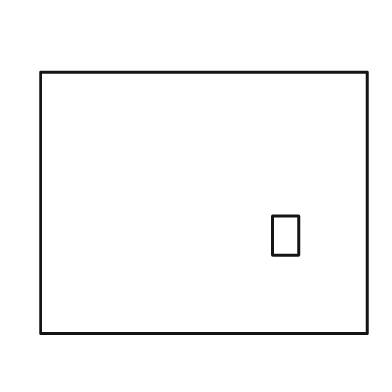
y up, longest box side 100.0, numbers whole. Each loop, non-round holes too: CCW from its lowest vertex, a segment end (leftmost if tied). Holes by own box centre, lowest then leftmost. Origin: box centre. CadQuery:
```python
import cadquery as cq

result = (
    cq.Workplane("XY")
    .moveTo(-50.0, -40.0)
    .lineTo(50.0, -40.0)
    .lineTo(50.0, 40.0)
    .lineTo(-50.0, 40.0)
    .close()
    .moveTo(21.0, -16.0)
    .lineTo(29.0, -16.0)
    .lineTo(29.0, -4.0)
    .lineTo(21.0, -4.0)
    .close()
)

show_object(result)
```